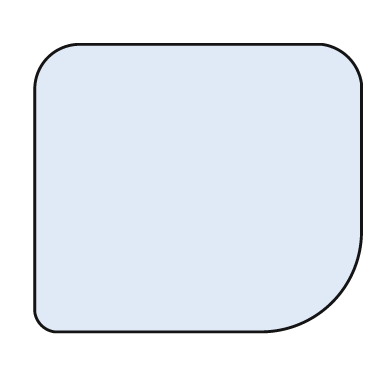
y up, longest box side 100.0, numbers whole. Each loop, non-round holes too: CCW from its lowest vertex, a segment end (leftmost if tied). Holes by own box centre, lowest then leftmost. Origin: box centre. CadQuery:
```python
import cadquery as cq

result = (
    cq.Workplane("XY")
    .moveTo(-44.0, -44.0)
    .lineTo(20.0, -44.0)
    .threePointArc((41.0, -35.0), (50.0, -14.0))
    .lineTo(50.0, 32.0)
    .threePointArc((46.0, 40.0), (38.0, 44.0))
    .lineTo(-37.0, 44.0)
    .threePointArc((-46.0, 40.0), (-50.0, 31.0))
    .lineTo(-50.0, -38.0)
    .threePointArc((-48.0, -42.0), (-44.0, -44.0))
    .close()
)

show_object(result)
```